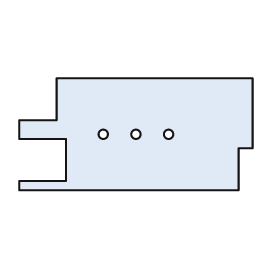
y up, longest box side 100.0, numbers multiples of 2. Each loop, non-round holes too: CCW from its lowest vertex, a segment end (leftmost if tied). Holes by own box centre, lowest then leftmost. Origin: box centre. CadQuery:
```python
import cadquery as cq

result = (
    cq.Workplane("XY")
    .moveTo(-50.0, -24.0)
    .lineTo(44.0, -24.0)
    .lineTo(44.0, -6.0)
    .lineTo(50.0, -6.0)
    .lineTo(50.0, 24.0)
    .lineTo(-34.0, 24.0)
    .lineTo(-34.0, 6.0)
    .lineTo(-50.0, 6.0)
    .lineTo(-50.0, -2.0)
    .lineTo(-30.0, -2.0)
    .lineTo(-30.0, -20.0)
    .lineTo(-50.0, -20.0)
    .close()
    .moveTo(-14.0, 0.0)
    .circle(2.0)
    .moveTo(0.0, 0.0)
    .circle(2.0)
    .moveTo(14.0, 0.0)
    .circle(2.0)
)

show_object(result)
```